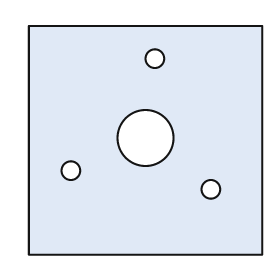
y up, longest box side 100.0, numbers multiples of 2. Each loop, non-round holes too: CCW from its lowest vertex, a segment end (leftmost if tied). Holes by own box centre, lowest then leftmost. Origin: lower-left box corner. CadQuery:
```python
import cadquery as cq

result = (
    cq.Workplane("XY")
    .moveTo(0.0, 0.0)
    .lineTo(100.0, 0.0)
    .lineTo(100.0, 98.0)
    .lineTo(0.0, 98.0)
    .close()
    .moveTo(78.0, 28.0)
    .circle(4.0)
    .moveTo(18.0, 36.0)
    .circle(4.0)
    .moveTo(50.0, 50.0)
    .circle(12.0)
    .moveTo(54.0, 84.0)
    .circle(4.0)
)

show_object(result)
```